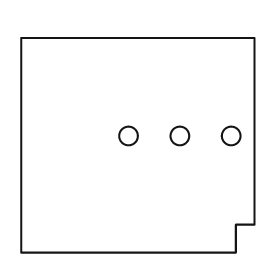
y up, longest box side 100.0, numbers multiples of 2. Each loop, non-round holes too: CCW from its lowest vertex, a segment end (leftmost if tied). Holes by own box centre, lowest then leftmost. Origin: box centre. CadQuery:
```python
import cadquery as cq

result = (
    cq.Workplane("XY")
    .moveTo(-50.0, -46.0)
    .lineTo(42.0, -46.0)
    .lineTo(42.0, -34.0)
    .lineTo(50.0, -34.0)
    .lineTo(50.0, 46.0)
    .lineTo(-50.0, 46.0)
    .close()
    .moveTo(-4.0, 4.0)
    .circle(4.0)
    .moveTo(18.0, 4.0)
    .circle(4.0)
    .moveTo(40.0, 4.0)
    .circle(4.0)
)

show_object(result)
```